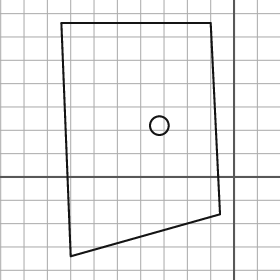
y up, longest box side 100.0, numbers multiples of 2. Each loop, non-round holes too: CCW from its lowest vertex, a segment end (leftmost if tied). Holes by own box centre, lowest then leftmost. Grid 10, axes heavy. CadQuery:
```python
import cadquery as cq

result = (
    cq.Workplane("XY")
    .moveTo(-70.0, -34.0)
    .lineTo(-6.0, -16.0)
    .lineTo(-10.0, 66.0)
    .lineTo(-74.0, 66.0)
    .close()
    .moveTo(-32.0, 22.0)
    .circle(4.0)
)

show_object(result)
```